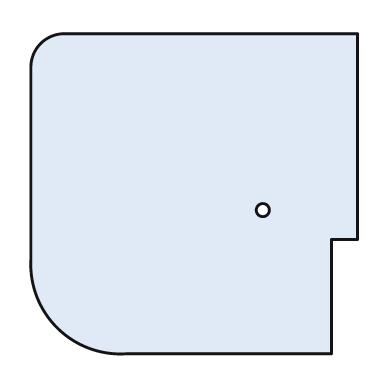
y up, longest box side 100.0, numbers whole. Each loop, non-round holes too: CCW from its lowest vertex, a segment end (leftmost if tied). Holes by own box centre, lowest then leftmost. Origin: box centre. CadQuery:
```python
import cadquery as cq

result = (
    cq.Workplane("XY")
    .moveTo(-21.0, -49.0)
    .lineTo(42.0, -49.0)
    .lineTo(42.0, -14.0)
    .lineTo(50.0, -14.0)
    .lineTo(50.0, 49.0)
    .lineTo(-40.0, 49.0)
    .threePointArc((-47.0, 46.0), (-50.0, 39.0))
    .lineTo(-50.0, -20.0)
    .threePointArc((-42.0, -41.0), (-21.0, -49.0))
    .close()
    .moveTo(21.0, -5.0)
    .circle(2.0)
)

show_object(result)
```